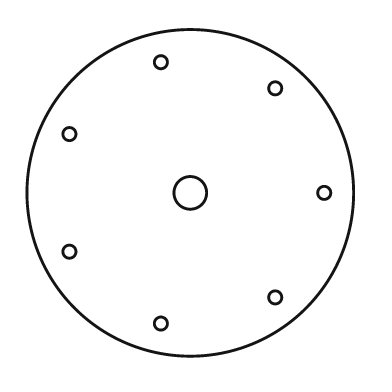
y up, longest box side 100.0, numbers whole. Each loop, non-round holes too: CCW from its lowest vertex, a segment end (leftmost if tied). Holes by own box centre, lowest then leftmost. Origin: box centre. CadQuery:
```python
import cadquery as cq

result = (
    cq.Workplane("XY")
    .moveTo(0.0, 0.0)
    .circle(50.0)
    .moveTo(-9.0, -40.0)
    .circle(2.0)
    .moveTo(26.0, -32.0)
    .circle(2.0)
    .moveTo(-37.0, -18.0)
    .circle(2.0)
    .moveTo(0.0, 0.0)
    .circle(5.0)
    .moveTo(41.0, 0.0)
    .circle(2.0)
    .moveTo(-37.0, 18.0)
    .circle(2.0)
    .moveTo(26.0, 32.0)
    .circle(2.0)
    .moveTo(-9.0, 40.0)
    .circle(2.0)
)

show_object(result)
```